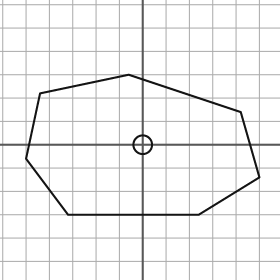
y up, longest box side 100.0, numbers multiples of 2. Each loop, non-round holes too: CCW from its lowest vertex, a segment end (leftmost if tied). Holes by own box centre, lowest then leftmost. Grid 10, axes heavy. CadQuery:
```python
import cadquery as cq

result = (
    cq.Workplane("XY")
    .moveTo(-32.0, -30.0)
    .lineTo(24.0, -30.0)
    .lineTo(50.0, -14.0)
    .lineTo(42.0, 14.0)
    .lineTo(-6.0, 30.0)
    .lineTo(-44.0, 22.0)
    .lineTo(-50.0, -6.0)
    .close()
    .moveTo(0.0, 0.0)
    .circle(4.0)
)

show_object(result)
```